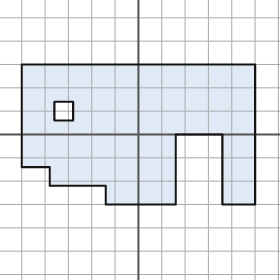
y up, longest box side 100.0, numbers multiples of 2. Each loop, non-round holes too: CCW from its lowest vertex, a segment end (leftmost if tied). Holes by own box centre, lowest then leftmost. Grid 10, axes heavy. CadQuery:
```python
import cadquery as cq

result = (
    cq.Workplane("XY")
    .moveTo(-14.0, -30.0)
    .lineTo(16.0, -30.0)
    .lineTo(16.0, 0.0)
    .lineTo(36.0, 0.0)
    .lineTo(36.0, -30.0)
    .lineTo(50.0, -30.0)
    .lineTo(50.0, 30.0)
    .lineTo(-50.0, 30.0)
    .lineTo(-50.0, -14.0)
    .lineTo(-38.0, -14.0)
    .lineTo(-38.0, -22.0)
    .lineTo(-14.0, -22.0)
    .close()
    .moveTo(-36.0, 6.0)
    .lineTo(-28.0, 6.0)
    .lineTo(-28.0, 14.0)
    .lineTo(-36.0, 14.0)
    .close()
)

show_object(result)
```